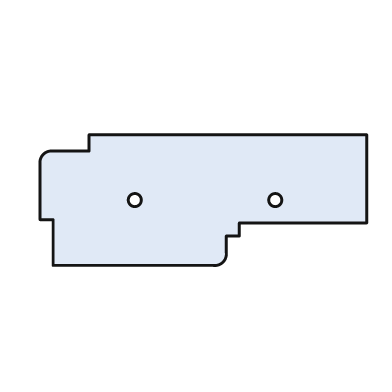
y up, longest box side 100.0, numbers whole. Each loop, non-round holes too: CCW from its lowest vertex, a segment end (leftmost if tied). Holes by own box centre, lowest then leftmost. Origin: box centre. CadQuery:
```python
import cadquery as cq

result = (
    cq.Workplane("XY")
    .moveTo(-46.0, -20.0)
    .lineTo(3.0, -20.0)
    .threePointArc((6.0, -19.0), (7.0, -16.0))
    .lineTo(7.0, -11.0)
    .lineTo(11.0, -11.0)
    .lineTo(11.0, -7.0)
    .lineTo(50.0, -7.0)
    .lineTo(50.0, 20.0)
    .lineTo(-35.0, 20.0)
    .lineTo(-35.0, 15.0)
    .lineTo(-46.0, 15.0)
    .threePointArc((-49.0, 14.0), (-50.0, 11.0))
    .lineTo(-50.0, -6.0)
    .lineTo(-46.0, -6.0)
    .close()
    .moveTo(-21.0, 0.0)
    .circle(2.0)
    .moveTo(22.0, 0.0)
    .circle(2.0)
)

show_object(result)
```